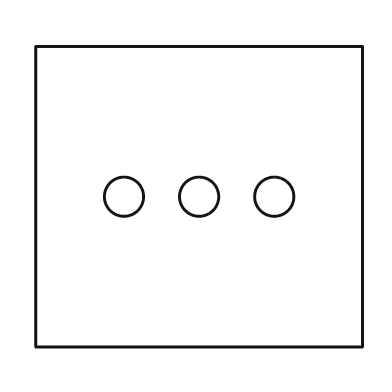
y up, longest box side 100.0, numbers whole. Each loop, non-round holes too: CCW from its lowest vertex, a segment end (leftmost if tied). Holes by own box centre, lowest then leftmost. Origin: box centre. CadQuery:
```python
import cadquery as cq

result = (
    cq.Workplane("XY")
    .moveTo(-50.0, -46.0)
    .lineTo(50.0, -46.0)
    .lineTo(50.0, 46.0)
    .lineTo(-50.0, 46.0)
    .close()
    .moveTo(-23.0, 0.0)
    .circle(6.0)
    .moveTo(0.0, 0.0)
    .circle(6.0)
    .moveTo(23.0, 0.0)
    .circle(6.0)
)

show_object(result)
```